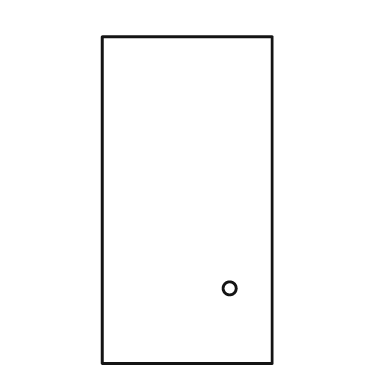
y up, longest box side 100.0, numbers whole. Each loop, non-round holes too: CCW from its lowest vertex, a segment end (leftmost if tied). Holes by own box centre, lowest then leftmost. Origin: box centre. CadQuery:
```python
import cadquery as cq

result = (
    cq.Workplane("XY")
    .moveTo(-26.0, -50.0)
    .lineTo(26.0, -50.0)
    .lineTo(26.0, 50.0)
    .lineTo(-26.0, 50.0)
    .close()
    .moveTo(13.0, -27.0)
    .circle(2.0)
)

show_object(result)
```